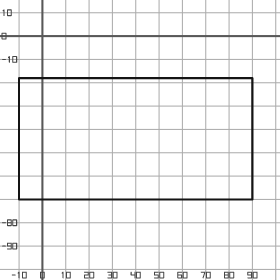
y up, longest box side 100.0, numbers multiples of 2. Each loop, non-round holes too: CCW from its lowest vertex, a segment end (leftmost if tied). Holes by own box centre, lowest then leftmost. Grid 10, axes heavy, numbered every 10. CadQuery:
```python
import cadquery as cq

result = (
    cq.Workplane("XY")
    .moveTo(-10.0, -70.0)
    .lineTo(90.0, -70.0)
    .lineTo(90.0, -18.0)
    .lineTo(-10.0, -18.0)
    .close()
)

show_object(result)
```